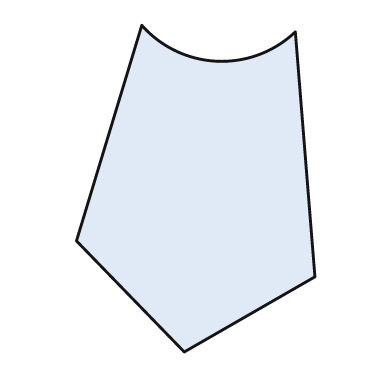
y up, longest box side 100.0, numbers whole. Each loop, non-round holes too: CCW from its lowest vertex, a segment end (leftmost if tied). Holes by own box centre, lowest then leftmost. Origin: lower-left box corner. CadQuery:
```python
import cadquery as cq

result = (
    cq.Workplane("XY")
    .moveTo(33.0, 0.0)
    .lineTo(73.0, 23.0)
    .lineTo(67.0, 98.0)
    .threePointArc((43.0, 89.0), (20.0, 100.0))
    .lineTo(0.0, 34.0)
    .close()
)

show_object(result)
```